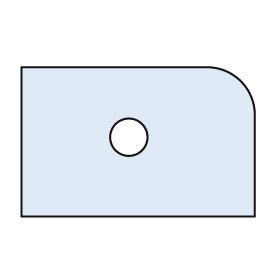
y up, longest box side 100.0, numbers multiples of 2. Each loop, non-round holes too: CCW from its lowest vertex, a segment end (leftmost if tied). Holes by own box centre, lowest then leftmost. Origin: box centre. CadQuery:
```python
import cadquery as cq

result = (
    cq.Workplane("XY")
    .moveTo(-50.0, -32.0)
    .lineTo(50.0, -32.0)
    .lineTo(50.0, 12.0)
    .threePointArc((44.0, 26.0), (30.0, 32.0))
    .lineTo(-50.0, 32.0)
    .close()
    .moveTo(-4.0, 2.0)
    .circle(8.0)
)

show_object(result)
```